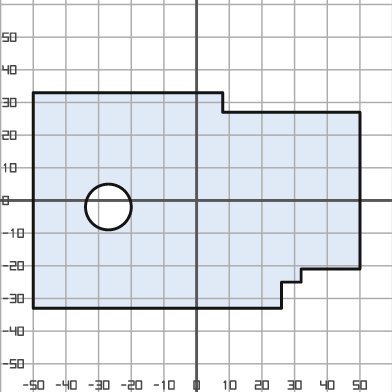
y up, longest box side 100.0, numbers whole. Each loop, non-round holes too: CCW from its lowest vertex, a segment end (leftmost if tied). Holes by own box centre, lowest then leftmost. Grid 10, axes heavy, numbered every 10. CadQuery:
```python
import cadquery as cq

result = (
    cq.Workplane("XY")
    .moveTo(-50.0, -33.0)
    .lineTo(26.0, -33.0)
    .lineTo(26.0, -25.0)
    .lineTo(32.0, -25.0)
    .lineTo(32.0, -21.0)
    .lineTo(50.0, -21.0)
    .lineTo(50.0, 27.0)
    .lineTo(8.0, 27.0)
    .lineTo(8.0, 33.0)
    .lineTo(-50.0, 33.0)
    .close()
    .moveTo(-27.0, -2.0)
    .circle(7.0)
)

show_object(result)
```